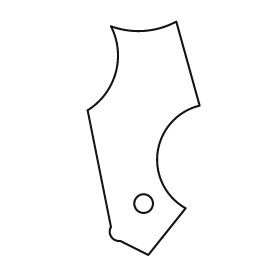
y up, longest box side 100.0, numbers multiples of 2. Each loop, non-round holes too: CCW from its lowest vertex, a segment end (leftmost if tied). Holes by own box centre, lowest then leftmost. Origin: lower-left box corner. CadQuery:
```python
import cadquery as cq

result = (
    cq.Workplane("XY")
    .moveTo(26.0, 0.0)
    .lineTo(42.0, 20.0)
    .threePointArc((30.0, 44.0), (48.0, 64.0))
    .lineTo(38.0, 100.0)
    .threePointArc((24.0, 96.0), (10.0, 98.0))
    .threePointArc((12.0, 78.0), (0.0, 62.0))
    .lineTo(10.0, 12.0)
    .threePointArc((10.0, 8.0), (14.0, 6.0))
    .close()
    .moveTo(24.0, 22.0)
    .circle(4.0)
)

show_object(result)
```